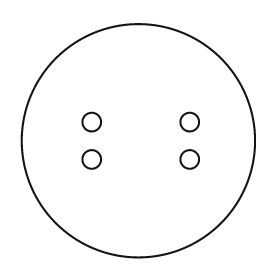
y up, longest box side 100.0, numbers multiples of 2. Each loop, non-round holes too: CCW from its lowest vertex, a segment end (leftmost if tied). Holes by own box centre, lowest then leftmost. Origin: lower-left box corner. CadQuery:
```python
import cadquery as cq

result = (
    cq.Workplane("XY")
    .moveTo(50.0, 50.0)
    .circle(50.0)
    .moveTo(30.0, 42.0)
    .circle(4.0)
    .moveTo(72.0, 42.0)
    .circle(4.0)
    .moveTo(30.0, 58.0)
    .circle(4.0)
    .moveTo(72.0, 58.0)
    .circle(4.0)
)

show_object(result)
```